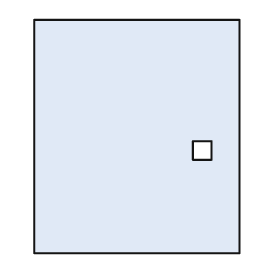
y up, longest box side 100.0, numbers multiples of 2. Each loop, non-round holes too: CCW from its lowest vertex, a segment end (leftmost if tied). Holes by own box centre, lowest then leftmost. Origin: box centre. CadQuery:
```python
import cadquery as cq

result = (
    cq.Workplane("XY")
    .moveTo(-44.0, -50.0)
    .lineTo(44.0, -50.0)
    .lineTo(44.0, 50.0)
    .lineTo(-44.0, 50.0)
    .close()
    .moveTo(24.0, -10.0)
    .lineTo(32.0, -10.0)
    .lineTo(32.0, -2.0)
    .lineTo(24.0, -2.0)
    .close()
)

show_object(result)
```